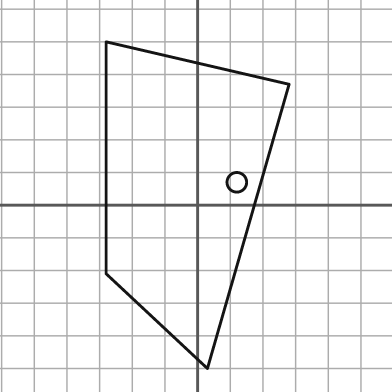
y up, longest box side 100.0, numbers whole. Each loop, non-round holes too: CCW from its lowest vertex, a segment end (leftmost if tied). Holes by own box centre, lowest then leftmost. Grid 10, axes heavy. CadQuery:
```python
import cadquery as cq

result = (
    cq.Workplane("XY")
    .moveTo(3.0, -50.0)
    .lineTo(28.0, 37.0)
    .lineTo(-28.0, 50.0)
    .lineTo(-28.0, -21.0)
    .close()
    .moveTo(12.0, 7.0)
    .circle(3.0)
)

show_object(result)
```